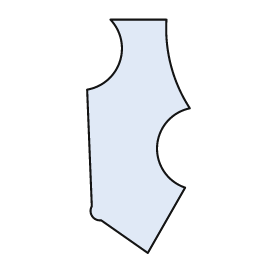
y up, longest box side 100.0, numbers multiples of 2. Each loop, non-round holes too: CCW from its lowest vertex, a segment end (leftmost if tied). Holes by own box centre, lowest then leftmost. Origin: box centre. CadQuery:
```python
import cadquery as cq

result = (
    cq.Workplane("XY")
    .moveTo(4.0, -50.0)
    .lineTo(20.0, -22.0)
    .threePointArc((8.0, -4.0), (22.0, 12.0))
    .threePointArc((14.0, 30.0), (12.0, 50.0))
    .lineTo(-12.0, 50.0)
    .threePointArc((-8.0, 32.0), (-22.0, 20.0))
    .lineTo(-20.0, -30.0)
    .threePointArc((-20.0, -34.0), (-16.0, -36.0))
    .close()
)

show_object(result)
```